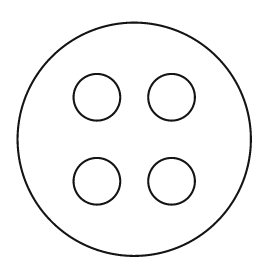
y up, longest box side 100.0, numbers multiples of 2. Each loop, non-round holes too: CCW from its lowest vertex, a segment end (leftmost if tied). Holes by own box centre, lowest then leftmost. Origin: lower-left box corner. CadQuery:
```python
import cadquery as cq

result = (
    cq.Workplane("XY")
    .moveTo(50.0, 50.0)
    .circle(50.0)
    .moveTo(34.0, 32.0)
    .circle(10.0)
    .moveTo(66.0, 32.0)
    .circle(10.0)
    .moveTo(34.0, 68.0)
    .circle(10.0)
    .moveTo(66.0, 68.0)
    .circle(10.0)
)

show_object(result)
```